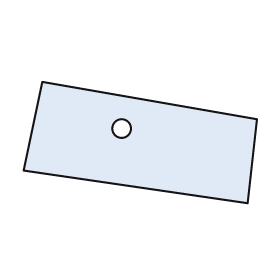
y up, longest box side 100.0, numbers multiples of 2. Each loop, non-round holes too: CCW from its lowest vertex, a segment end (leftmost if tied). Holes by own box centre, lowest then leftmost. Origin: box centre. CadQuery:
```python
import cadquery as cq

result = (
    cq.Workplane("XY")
    .moveTo(46.0, -26.0)
    .lineTo(50.0, 10.0)
    .lineTo(-42.0, 26.0)
    .lineTo(-50.0, -12.0)
    .close()
    .moveTo(-8.0, 6.0)
    .circle(4.0)
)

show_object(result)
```